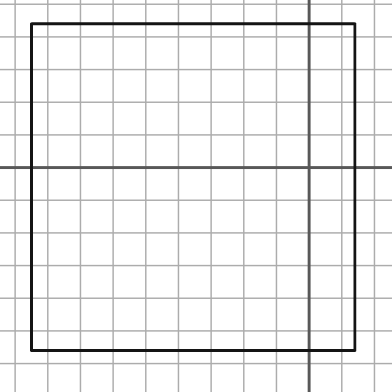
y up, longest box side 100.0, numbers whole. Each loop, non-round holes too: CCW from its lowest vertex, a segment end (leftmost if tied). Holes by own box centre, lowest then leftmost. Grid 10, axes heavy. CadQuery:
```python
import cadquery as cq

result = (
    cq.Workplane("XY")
    .moveTo(-85.0, -56.0)
    .lineTo(14.0, -56.0)
    .lineTo(14.0, 44.0)
    .lineTo(-85.0, 44.0)
    .close()
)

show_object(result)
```